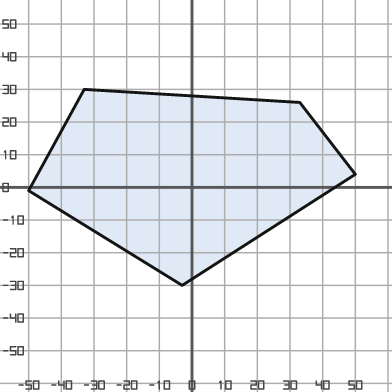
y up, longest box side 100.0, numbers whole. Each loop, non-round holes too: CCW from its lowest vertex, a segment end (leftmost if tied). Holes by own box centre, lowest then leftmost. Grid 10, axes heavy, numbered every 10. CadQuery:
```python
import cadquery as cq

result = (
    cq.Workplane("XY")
    .moveTo(-3.0, -30.0)
    .lineTo(50.0, 4.0)
    .lineTo(33.0, 26.0)
    .lineTo(-33.0, 30.0)
    .lineTo(-50.0, -1.0)
    .close()
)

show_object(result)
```